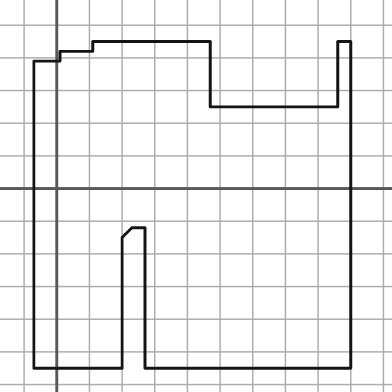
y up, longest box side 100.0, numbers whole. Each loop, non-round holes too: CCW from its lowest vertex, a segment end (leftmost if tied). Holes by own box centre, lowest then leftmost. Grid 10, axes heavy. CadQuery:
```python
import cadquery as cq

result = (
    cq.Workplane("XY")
    .moveTo(-7.0, -55.0)
    .lineTo(20.0, -55.0)
    .lineTo(20.0, -15.0)
    .lineTo(23.0, -12.0)
    .lineTo(27.0, -12.0)
    .lineTo(27.0, -55.0)
    .lineTo(90.0, -55.0)
    .lineTo(90.0, 45.0)
    .lineTo(86.0, 45.0)
    .lineTo(86.0, 25.0)
    .lineTo(47.0, 25.0)
    .lineTo(47.0, 45.0)
    .lineTo(11.0, 45.0)
    .lineTo(11.0, 42.0)
    .lineTo(1.0, 42.0)
    .lineTo(1.0, 39.0)
    .lineTo(-7.0, 39.0)
    .close()
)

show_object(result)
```